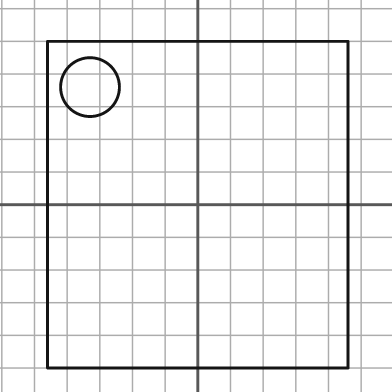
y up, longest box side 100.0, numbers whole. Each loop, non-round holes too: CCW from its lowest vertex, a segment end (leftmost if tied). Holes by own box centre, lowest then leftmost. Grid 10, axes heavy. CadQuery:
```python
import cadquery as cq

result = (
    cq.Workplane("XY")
    .moveTo(-46.0, -50.0)
    .lineTo(46.0, -50.0)
    .lineTo(46.0, 50.0)
    .lineTo(-46.0, 50.0)
    .close()
    .moveTo(-33.0, 36.0)
    .circle(9.0)
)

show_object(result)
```